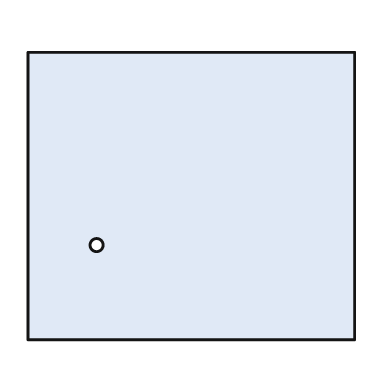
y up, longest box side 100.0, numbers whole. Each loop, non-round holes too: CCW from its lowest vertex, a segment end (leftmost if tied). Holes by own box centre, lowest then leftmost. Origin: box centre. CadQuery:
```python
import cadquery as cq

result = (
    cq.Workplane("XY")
    .moveTo(-50.0, -44.0)
    .lineTo(50.0, -44.0)
    .lineTo(50.0, 44.0)
    .lineTo(-50.0, 44.0)
    .close()
    .moveTo(-29.0, -15.0)
    .circle(2.0)
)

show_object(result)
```